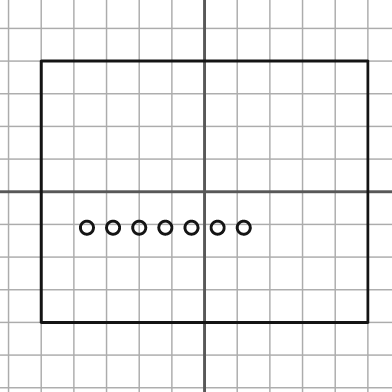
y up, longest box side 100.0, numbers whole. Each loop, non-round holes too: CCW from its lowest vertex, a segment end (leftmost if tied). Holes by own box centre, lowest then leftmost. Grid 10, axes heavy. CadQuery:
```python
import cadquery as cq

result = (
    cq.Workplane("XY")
    .moveTo(-50.0, -40.0)
    .lineTo(50.0, -40.0)
    .lineTo(50.0, 40.0)
    .lineTo(-50.0, 40.0)
    .close()
    .moveTo(-36.0, -11.0)
    .circle(2.0)
    .moveTo(-28.0, -11.0)
    .circle(2.0)
    .moveTo(-20.0, -11.0)
    .circle(2.0)
    .moveTo(-12.0, -11.0)
    .circle(2.0)
    .moveTo(-4.0, -11.0)
    .circle(2.0)
    .moveTo(4.0, -11.0)
    .circle(2.0)
    .moveTo(12.0, -11.0)
    .circle(2.0)
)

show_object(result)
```